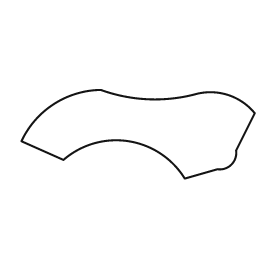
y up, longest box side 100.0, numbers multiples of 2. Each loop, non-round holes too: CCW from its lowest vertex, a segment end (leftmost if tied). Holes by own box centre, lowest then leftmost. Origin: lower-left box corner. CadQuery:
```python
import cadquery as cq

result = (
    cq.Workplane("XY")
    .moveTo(70.0, 0.0)
    .lineTo(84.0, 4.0)
    .threePointArc((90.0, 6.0), (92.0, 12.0))
    .lineTo(100.0, 28.0)
    .threePointArc((88.0, 36.0), (74.0, 36.0))
    .threePointArc((54.0, 34.0), (34.0, 38.0))
    .threePointArc((14.0, 32.0), (0.0, 16.0))
    .lineTo(18.0, 8.0)
    .threePointArc((46.0, 16.0), (70.0, 0.0))
    .close()
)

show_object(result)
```